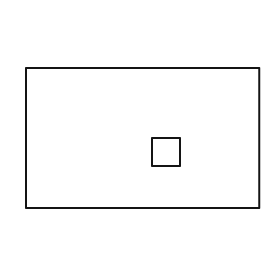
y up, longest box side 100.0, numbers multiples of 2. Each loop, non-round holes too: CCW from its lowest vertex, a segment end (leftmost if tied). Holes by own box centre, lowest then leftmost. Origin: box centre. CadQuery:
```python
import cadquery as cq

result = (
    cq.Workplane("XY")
    .moveTo(-50.0, -30.0)
    .lineTo(50.0, -30.0)
    .lineTo(50.0, 30.0)
    .lineTo(-50.0, 30.0)
    .close()
    .moveTo(4.0, -12.0)
    .lineTo(16.0, -12.0)
    .lineTo(16.0, 0.0)
    .lineTo(4.0, 0.0)
    .close()
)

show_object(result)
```